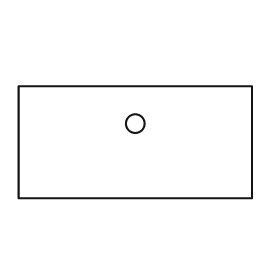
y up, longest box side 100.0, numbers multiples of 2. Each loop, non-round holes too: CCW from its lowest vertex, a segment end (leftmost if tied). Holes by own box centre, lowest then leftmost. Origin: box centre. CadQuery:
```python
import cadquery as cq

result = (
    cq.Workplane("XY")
    .moveTo(-50.0, -24.0)
    .lineTo(50.0, -24.0)
    .lineTo(50.0, 24.0)
    .lineTo(-50.0, 24.0)
    .close()
    .moveTo(0.0, 8.0)
    .circle(4.0)
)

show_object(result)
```